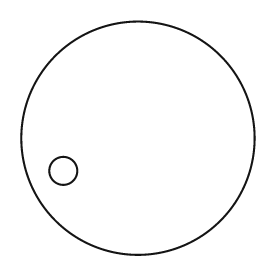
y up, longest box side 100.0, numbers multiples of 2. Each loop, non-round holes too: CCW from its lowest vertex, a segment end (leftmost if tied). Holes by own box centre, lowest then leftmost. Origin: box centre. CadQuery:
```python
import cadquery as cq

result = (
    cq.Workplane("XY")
    .moveTo(0.0, 0.0)
    .circle(50.0)
    .moveTo(-32.0, -14.0)
    .circle(6.0)
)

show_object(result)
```